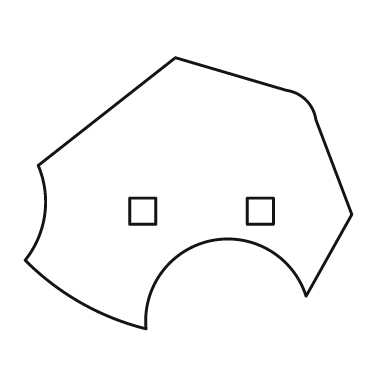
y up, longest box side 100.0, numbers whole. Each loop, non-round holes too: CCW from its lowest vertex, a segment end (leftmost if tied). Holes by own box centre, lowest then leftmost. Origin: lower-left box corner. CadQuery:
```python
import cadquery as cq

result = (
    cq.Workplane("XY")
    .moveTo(37.0, 0.0)
    .threePointArc((57.0, 27.0), (86.0, 10.0))
    .lineTo(100.0, 35.0)
    .lineTo(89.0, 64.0)
    .threePointArc((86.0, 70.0), (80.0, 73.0))
    .lineTo(46.0, 83.0)
    .lineTo(4.0, 50.0)
    .threePointArc((6.0, 35.0), (0.0, 21.0))
    .threePointArc((17.0, 8.0), (37.0, 0.0))
    .close()
    .moveTo(32.0, 32.0)
    .lineTo(40.0, 32.0)
    .lineTo(40.0, 40.0)
    .lineTo(32.0, 40.0)
    .close()
    .moveTo(68.0, 32.0)
    .lineTo(76.0, 32.0)
    .lineTo(76.0, 40.0)
    .lineTo(68.0, 40.0)
    .close()
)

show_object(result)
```